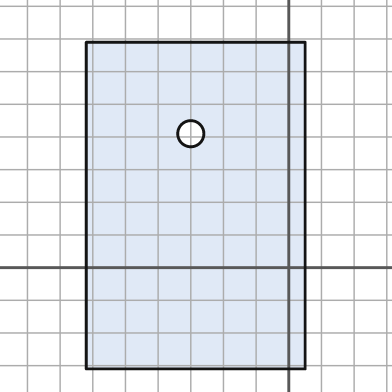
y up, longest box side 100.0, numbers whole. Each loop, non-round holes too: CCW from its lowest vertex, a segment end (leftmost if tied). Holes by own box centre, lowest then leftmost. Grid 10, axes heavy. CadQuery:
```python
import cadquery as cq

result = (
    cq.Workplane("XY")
    .moveTo(-62.0, -31.0)
    .lineTo(5.0, -31.0)
    .lineTo(5.0, 69.0)
    .lineTo(-62.0, 69.0)
    .close()
    .moveTo(-30.0, 41.0)
    .circle(4.0)
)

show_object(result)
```